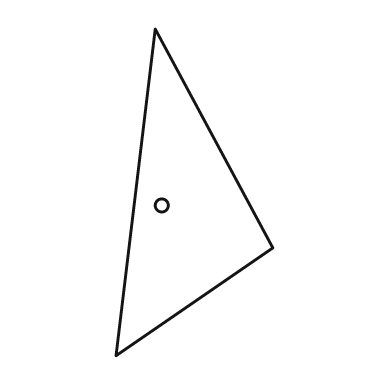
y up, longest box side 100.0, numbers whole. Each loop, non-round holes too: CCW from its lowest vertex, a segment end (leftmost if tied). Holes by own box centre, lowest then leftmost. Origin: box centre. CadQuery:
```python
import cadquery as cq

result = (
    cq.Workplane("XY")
    .moveTo(-24.0, -50.0)
    .lineTo(24.0, -17.0)
    .lineTo(-12.0, 50.0)
    .close()
    .moveTo(-10.0, -4.0)
    .circle(2.0)
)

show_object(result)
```